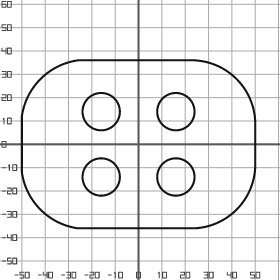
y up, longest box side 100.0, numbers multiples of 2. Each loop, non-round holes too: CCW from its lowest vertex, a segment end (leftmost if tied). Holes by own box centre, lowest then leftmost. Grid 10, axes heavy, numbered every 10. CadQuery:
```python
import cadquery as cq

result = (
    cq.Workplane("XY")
    .moveTo(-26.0, -36.0)
    .lineTo(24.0, -36.0)
    .threePointArc((42.0, -28.0), (50.0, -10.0))
    .lineTo(50.0, 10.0)
    .threePointArc((42.0, 28.0), (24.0, 36.0))
    .lineTo(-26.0, 36.0)
    .threePointArc((-42.0, 28.0), (-50.0, 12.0))
    .lineTo(-50.0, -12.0)
    .threePointArc((-42.0, -28.0), (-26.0, -36.0))
    .close()
    .moveTo(-16.0, -14.0)
    .circle(8.0)
    .moveTo(16.0, -14.0)
    .circle(8.0)
    .moveTo(-16.0, 14.0)
    .circle(8.0)
    .moveTo(16.0, 14.0)
    .circle(8.0)
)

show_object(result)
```